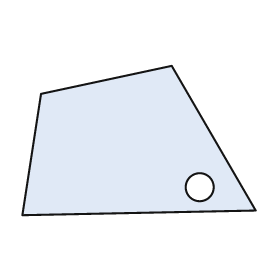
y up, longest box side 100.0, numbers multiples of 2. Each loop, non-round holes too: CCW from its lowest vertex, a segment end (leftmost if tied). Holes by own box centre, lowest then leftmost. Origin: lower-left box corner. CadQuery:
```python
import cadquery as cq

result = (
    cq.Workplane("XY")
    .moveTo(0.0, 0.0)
    .lineTo(100.0, 2.0)
    .lineTo(64.0, 64.0)
    .lineTo(8.0, 52.0)
    .close()
    .moveTo(76.0, 12.0)
    .circle(6.0)
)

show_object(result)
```